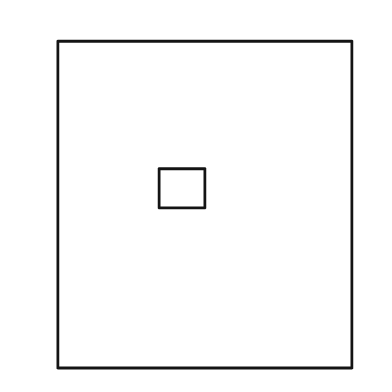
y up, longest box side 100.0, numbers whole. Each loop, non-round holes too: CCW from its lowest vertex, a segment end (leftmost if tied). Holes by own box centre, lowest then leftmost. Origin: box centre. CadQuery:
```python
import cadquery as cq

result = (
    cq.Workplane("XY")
    .moveTo(-45.0, -50.0)
    .lineTo(45.0, -50.0)
    .lineTo(45.0, 50.0)
    .lineTo(-45.0, 50.0)
    .close()
    .moveTo(-14.0, -1.0)
    .lineTo(0.0, -1.0)
    .lineTo(0.0, 11.0)
    .lineTo(-14.0, 11.0)
    .close()
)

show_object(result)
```